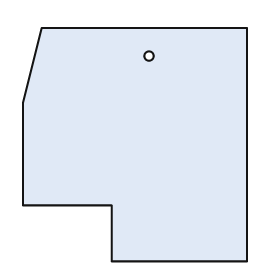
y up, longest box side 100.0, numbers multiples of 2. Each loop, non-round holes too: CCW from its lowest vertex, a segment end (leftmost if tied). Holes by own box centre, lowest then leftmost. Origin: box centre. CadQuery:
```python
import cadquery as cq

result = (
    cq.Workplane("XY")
    .moveTo(-10.0, -50.0)
    .lineTo(48.0, -50.0)
    .lineTo(48.0, 50.0)
    .lineTo(-40.0, 50.0)
    .lineTo(-48.0, 18.0)
    .lineTo(-48.0, -26.0)
    .lineTo(-10.0, -26.0)
    .close()
    .moveTo(6.0, 38.0)
    .circle(2.0)
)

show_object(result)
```